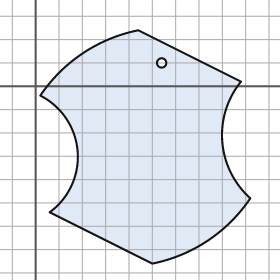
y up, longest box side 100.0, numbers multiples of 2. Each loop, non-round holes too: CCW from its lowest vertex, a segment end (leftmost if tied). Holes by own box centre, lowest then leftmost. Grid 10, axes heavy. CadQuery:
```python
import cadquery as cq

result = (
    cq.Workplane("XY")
    .moveTo(50.0, -76.0)
    .threePointArc((74.0, -66.0), (92.0, -48.0))
    .threePointArc((80.0, -24.0), (88.0, 2.0))
    .lineTo(44.0, 24.0)
    .threePointArc((20.0, 14.0), (2.0, -4.0))
    .threePointArc((18.0, -28.0), (6.0, -54.0))
    .close()
    .moveTo(54.0, 10.0)
    .circle(2.0)
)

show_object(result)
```